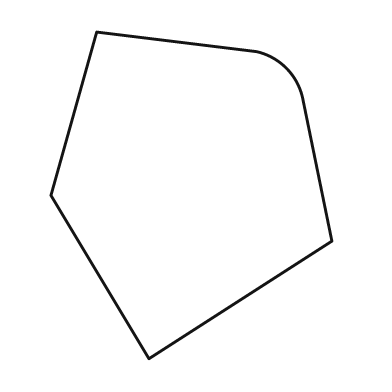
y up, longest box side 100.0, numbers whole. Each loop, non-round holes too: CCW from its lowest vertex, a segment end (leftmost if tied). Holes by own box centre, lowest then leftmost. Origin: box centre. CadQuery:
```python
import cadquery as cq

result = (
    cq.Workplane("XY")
    .moveTo(-13.0, -50.0)
    .lineTo(43.0, -14.0)
    .lineTo(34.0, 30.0)
    .threePointArc((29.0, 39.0), (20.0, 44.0))
    .lineTo(-29.0, 50.0)
    .lineTo(-43.0, 0.0)
    .close()
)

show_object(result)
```